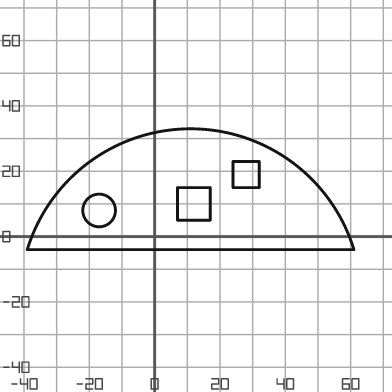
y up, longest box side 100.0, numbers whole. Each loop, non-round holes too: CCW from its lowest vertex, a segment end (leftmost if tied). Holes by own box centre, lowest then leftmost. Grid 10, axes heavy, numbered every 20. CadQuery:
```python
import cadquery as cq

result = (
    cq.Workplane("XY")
    .moveTo(-39.0, -4.0)
    .lineTo(61.0, -4.0)
    .threePointArc((11.0, 33.0), (-39.0, -4.0))
    .close()
    .moveTo(-17.0, 8.0)
    .circle(5.0)
    .moveTo(7.0, 5.0)
    .lineTo(17.0, 5.0)
    .lineTo(17.0, 15.0)
    .lineTo(7.0, 15.0)
    .close()
    .moveTo(24.0, 15.0)
    .lineTo(32.0, 15.0)
    .lineTo(32.0, 23.0)
    .lineTo(24.0, 23.0)
    .close()
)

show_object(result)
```